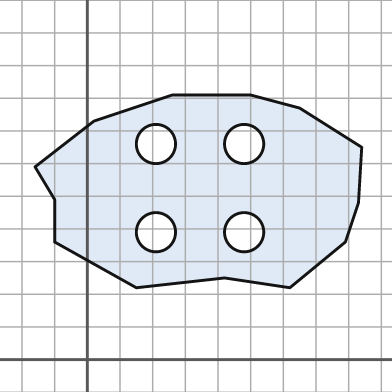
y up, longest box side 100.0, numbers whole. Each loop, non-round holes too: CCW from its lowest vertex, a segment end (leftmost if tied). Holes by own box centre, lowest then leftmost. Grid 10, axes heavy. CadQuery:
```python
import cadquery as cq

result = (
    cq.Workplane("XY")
    .moveTo(15.0, 22.0)
    .lineTo(42.0, 25.0)
    .lineTo(62.0, 22.0)
    .lineTo(79.0, 36.0)
    .lineTo(83.0, 48.0)
    .lineTo(84.0, 65.0)
    .lineTo(65.0, 77.0)
    .lineTo(50.0, 81.0)
    .lineTo(26.0, 81.0)
    .lineTo(2.0, 73.0)
    .lineTo(-16.0, 59.0)
    .lineTo(-10.0, 49.0)
    .lineTo(-10.0, 36.0)
    .close()
    .moveTo(21.0, 39.0)
    .circle(6.0)
    .moveTo(48.0, 39.0)
    .circle(6.0)
    .moveTo(21.0, 66.0)
    .circle(6.0)
    .moveTo(48.0, 66.0)
    .circle(6.0)
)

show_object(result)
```